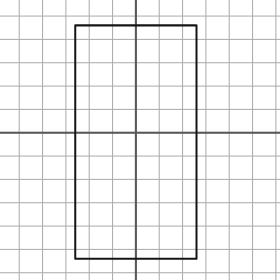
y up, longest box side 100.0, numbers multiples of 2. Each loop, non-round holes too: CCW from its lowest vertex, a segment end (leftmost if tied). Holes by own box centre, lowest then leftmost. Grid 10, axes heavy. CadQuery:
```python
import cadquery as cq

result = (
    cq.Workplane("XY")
    .moveTo(-26.0, -54.0)
    .lineTo(26.0, -54.0)
    .lineTo(26.0, 46.0)
    .lineTo(-26.0, 46.0)
    .close()
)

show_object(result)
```